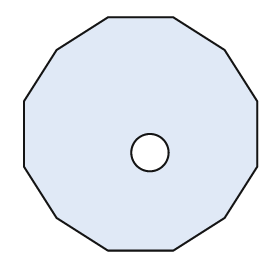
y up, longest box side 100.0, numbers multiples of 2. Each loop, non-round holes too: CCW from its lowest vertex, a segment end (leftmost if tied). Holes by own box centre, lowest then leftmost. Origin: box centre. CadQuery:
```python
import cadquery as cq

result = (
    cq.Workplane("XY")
    .moveTo(-14.0, -50.0)
    .lineTo(14.0, -50.0)
    .lineTo(36.0, -36.0)
    .lineTo(50.0, -14.0)
    .lineTo(50.0, 14.0)
    .lineTo(36.0, 36.0)
    .lineTo(14.0, 50.0)
    .lineTo(-14.0, 50.0)
    .lineTo(-36.0, 36.0)
    .lineTo(-50.0, 14.0)
    .lineTo(-50.0, -14.0)
    .lineTo(-36.0, -36.0)
    .close()
    .moveTo(4.0, -8.0)
    .circle(8.0)
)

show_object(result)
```